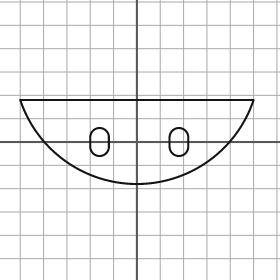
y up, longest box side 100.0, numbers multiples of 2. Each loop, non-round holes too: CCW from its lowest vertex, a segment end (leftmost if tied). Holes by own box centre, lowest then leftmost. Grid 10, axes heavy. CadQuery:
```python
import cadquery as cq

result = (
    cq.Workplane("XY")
    .moveTo(-50.0, 18.0)
    .threePointArc((0.0, -18.0), (50.0, 18.0))
    .close()
    .moveTo(-20.0, -2.0)
    .threePointArc((-16.0, -6.0), (-12.0, -2.0))
    .lineTo(-12.0, 2.0)
    .threePointArc((-16.0, 6.0), (-20.0, 2.0))
    .close()
    .moveTo(14.0, -2.0)
    .threePointArc((18.0, -6.0), (22.0, -2.0))
    .lineTo(22.0, 2.0)
    .threePointArc((18.0, 6.0), (14.0, 2.0))
    .close()
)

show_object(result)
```